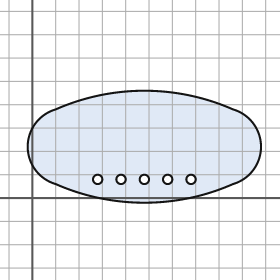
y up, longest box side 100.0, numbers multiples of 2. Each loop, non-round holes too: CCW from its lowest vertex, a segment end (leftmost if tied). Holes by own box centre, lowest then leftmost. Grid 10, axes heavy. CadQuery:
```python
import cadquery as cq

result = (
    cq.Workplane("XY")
    .moveTo(10.0, 6.0)
    .threePointArc((48.0, -2.0), (86.0, 6.0))
    .threePointArc((98.0, 22.0), (86.0, 38.0))
    .threePointArc((48.0, 46.0), (10.0, 38.0))
    .threePointArc((-2.0, 22.0), (10.0, 6.0))
    .close()
    .moveTo(28.0, 8.0)
    .circle(2.0)
    .moveTo(38.0, 8.0)
    .circle(2.0)
    .moveTo(48.0, 8.0)
    .circle(2.0)
    .moveTo(58.0, 8.0)
    .circle(2.0)
    .moveTo(68.0, 8.0)
    .circle(2.0)
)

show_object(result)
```